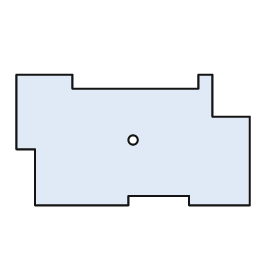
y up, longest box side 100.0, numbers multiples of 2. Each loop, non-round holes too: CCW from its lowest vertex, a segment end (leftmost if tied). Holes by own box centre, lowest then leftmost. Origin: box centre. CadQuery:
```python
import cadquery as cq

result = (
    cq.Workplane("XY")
    .moveTo(-42.0, -28.0)
    .lineTo(-2.0, -28.0)
    .lineTo(-2.0, -24.0)
    .lineTo(24.0, -24.0)
    .lineTo(24.0, -28.0)
    .lineTo(50.0, -28.0)
    .lineTo(50.0, 10.0)
    .lineTo(34.0, 10.0)
    .lineTo(34.0, 28.0)
    .lineTo(28.0, 28.0)
    .lineTo(28.0, 22.0)
    .lineTo(-26.0, 22.0)
    .lineTo(-26.0, 28.0)
    .lineTo(-50.0, 28.0)
    .lineTo(-50.0, -4.0)
    .lineTo(-42.0, -4.0)
    .close()
    .moveTo(0.0, 0.0)
    .circle(2.0)
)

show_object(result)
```